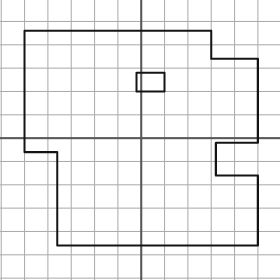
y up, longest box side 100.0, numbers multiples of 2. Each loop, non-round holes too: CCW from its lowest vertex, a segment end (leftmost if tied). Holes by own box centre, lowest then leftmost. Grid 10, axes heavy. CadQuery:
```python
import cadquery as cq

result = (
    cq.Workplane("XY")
    .moveTo(-36.0, -46.0)
    .lineTo(50.0, -46.0)
    .lineTo(50.0, -16.0)
    .lineTo(32.0, -16.0)
    .lineTo(32.0, -2.0)
    .lineTo(50.0, -2.0)
    .lineTo(50.0, 34.0)
    .lineTo(30.0, 34.0)
    .lineTo(30.0, 46.0)
    .lineTo(-50.0, 46.0)
    .lineTo(-50.0, -6.0)
    .lineTo(-36.0, -6.0)
    .close()
    .moveTo(-2.0, 20.0)
    .lineTo(10.0, 20.0)
    .lineTo(10.0, 28.0)
    .lineTo(-2.0, 28.0)
    .close()
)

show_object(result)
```